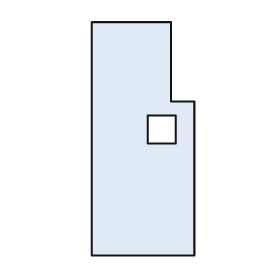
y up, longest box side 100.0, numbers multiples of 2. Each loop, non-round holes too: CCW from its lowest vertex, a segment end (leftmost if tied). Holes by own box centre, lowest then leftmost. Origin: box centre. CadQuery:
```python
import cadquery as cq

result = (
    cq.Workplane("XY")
    .moveTo(-22.0, -50.0)
    .lineTo(22.0, -50.0)
    .lineTo(22.0, 16.0)
    .lineTo(12.0, 16.0)
    .lineTo(12.0, 50.0)
    .lineTo(-22.0, 50.0)
    .close()
    .moveTo(2.0, -2.0)
    .lineTo(14.0, -2.0)
    .lineTo(14.0, 10.0)
    .lineTo(2.0, 10.0)
    .close()
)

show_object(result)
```